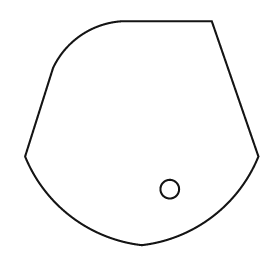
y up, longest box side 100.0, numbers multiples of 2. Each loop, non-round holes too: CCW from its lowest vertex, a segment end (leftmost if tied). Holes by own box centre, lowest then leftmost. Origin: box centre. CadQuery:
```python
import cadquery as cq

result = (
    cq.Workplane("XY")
    .moveTo(0.0, -48.0)
    .threePointArc((30.0, -36.0), (50.0, -10.0))
    .lineTo(30.0, 48.0)
    .lineTo(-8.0, 48.0)
    .threePointArc((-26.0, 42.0), (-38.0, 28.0))
    .lineTo(-50.0, -10.0)
    .threePointArc((-30.0, -36.0), (0.0, -48.0))
    .close()
    .moveTo(12.0, -24.0)
    .circle(4.0)
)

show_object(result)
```